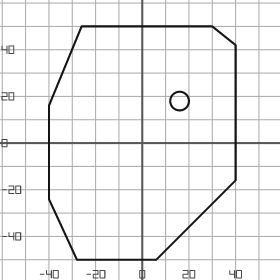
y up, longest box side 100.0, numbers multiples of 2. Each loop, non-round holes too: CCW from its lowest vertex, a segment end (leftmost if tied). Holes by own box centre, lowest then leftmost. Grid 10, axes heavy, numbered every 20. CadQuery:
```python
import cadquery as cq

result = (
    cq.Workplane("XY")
    .moveTo(-28.0, -50.0)
    .lineTo(6.0, -50.0)
    .lineTo(40.0, -16.0)
    .lineTo(40.0, 42.0)
    .lineTo(30.0, 50.0)
    .lineTo(-26.0, 50.0)
    .lineTo(-40.0, 16.0)
    .lineTo(-40.0, -24.0)
    .close()
    .moveTo(16.0, 18.0)
    .circle(4.0)
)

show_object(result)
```